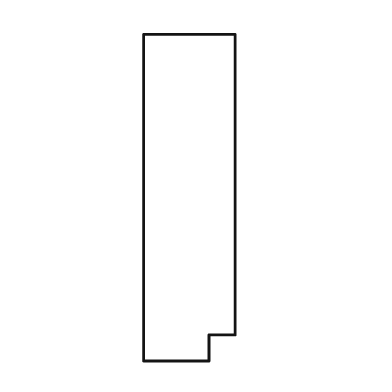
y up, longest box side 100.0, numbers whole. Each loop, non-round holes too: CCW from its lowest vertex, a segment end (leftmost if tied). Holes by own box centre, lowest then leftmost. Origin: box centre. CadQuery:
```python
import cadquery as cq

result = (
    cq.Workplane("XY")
    .moveTo(-14.0, -50.0)
    .lineTo(6.0, -50.0)
    .lineTo(6.0, -42.0)
    .lineTo(14.0, -42.0)
    .lineTo(14.0, 50.0)
    .lineTo(-14.0, 50.0)
    .close()
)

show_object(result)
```